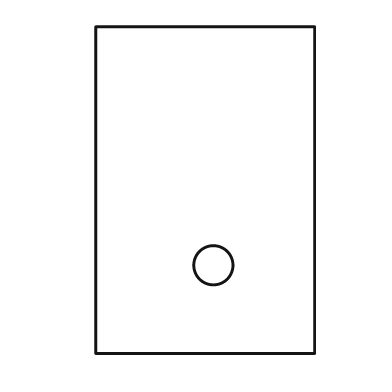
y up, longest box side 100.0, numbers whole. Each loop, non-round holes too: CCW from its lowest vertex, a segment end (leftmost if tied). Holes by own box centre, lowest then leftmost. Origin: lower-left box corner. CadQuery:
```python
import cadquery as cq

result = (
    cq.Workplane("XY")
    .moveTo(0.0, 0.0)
    .lineTo(67.0, 0.0)
    .lineTo(67.0, 100.0)
    .lineTo(0.0, 100.0)
    .close()
    .moveTo(36.0, 27.0)
    .circle(6.0)
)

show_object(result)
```